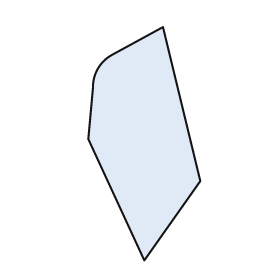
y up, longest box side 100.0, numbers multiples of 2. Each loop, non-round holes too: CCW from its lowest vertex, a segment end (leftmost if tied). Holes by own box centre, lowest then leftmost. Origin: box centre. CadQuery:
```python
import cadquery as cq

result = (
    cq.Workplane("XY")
    .moveTo(0.0, -50.0)
    .lineTo(24.0, -16.0)
    .lineTo(8.0, 50.0)
    .lineTo(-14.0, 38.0)
    .threePointArc((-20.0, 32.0), (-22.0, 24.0))
    .lineTo(-24.0, 2.0)
    .close()
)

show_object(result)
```